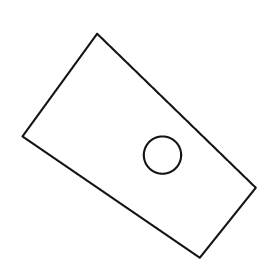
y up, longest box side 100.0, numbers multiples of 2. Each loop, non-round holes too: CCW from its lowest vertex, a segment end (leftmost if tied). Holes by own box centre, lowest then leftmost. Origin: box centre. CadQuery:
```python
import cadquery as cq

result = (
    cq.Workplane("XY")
    .moveTo(26.0, -48.0)
    .lineTo(50.0, -18.0)
    .lineTo(-18.0, 48.0)
    .lineTo(-50.0, 4.0)
    .close()
    .moveTo(10.0, -4.0)
    .circle(8.0)
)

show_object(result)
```